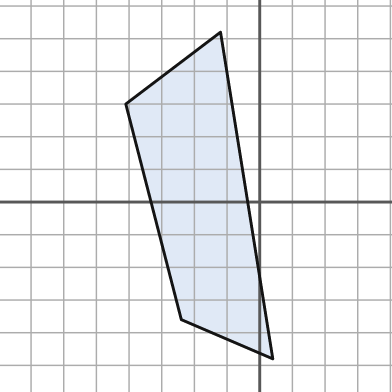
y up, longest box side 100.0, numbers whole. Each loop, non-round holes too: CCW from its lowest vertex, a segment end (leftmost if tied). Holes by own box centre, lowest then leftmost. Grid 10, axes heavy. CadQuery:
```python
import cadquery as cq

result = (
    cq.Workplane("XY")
    .moveTo(4.0, -48.0)
    .lineTo(-12.0, 52.0)
    .lineTo(-41.0, 30.0)
    .lineTo(-24.0, -36.0)
    .close()
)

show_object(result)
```